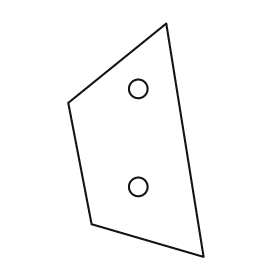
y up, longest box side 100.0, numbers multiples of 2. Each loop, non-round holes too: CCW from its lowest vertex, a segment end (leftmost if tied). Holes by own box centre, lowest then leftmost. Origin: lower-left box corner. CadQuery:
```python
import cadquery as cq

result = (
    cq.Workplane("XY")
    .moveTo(58.0, 0.0)
    .lineTo(42.0, 100.0)
    .lineTo(0.0, 66.0)
    .lineTo(10.0, 14.0)
    .close()
    .moveTo(30.0, 30.0)
    .circle(4.0)
    .moveTo(30.0, 72.0)
    .circle(4.0)
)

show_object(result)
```